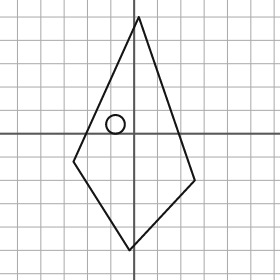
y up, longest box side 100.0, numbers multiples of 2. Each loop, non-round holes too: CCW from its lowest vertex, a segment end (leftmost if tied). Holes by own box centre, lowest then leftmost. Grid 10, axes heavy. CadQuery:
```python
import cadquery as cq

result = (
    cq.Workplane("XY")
    .moveTo(-2.0, -50.0)
    .lineTo(26.0, -20.0)
    .lineTo(2.0, 50.0)
    .lineTo(-26.0, -12.0)
    .close()
    .moveTo(-8.0, 4.0)
    .circle(4.0)
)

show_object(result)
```